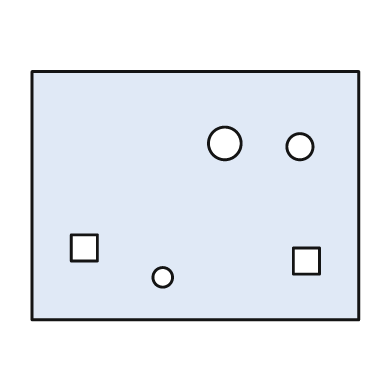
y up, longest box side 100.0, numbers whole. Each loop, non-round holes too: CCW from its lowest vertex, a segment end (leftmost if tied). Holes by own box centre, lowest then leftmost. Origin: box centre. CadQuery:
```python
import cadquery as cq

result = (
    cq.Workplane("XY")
    .moveTo(-50.0, -38.0)
    .lineTo(50.0, -38.0)
    .lineTo(50.0, 38.0)
    .lineTo(-50.0, 38.0)
    .close()
    .moveTo(-10.0, -25.0)
    .circle(3.0)
    .moveTo(30.0, -24.0)
    .lineTo(38.0, -24.0)
    .lineTo(38.0, -16.0)
    .lineTo(30.0, -16.0)
    .close()
    .moveTo(-38.0, -20.0)
    .lineTo(-30.0, -20.0)
    .lineTo(-30.0, -12.0)
    .lineTo(-38.0, -12.0)
    .close()
    .moveTo(32.0, 15.0)
    .circle(4.0)
    .moveTo(9.0, 16.0)
    .circle(5.0)
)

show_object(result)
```